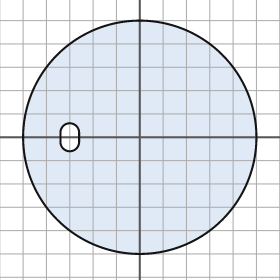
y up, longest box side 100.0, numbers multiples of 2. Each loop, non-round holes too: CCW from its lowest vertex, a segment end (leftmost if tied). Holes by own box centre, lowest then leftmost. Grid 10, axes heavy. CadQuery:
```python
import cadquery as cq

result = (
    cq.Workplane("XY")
    .moveTo(0.0, 0.0)
    .circle(50.0)
    .moveTo(-34.0, -2.0)
    .threePointArc((-30.0, -6.0), (-26.0, -2.0))
    .lineTo(-26.0, 2.0)
    .threePointArc((-30.0, 6.0), (-34.0, 2.0))
    .close()
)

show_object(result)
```